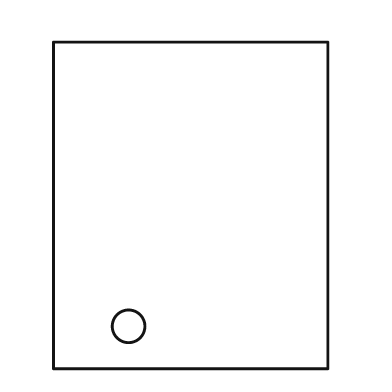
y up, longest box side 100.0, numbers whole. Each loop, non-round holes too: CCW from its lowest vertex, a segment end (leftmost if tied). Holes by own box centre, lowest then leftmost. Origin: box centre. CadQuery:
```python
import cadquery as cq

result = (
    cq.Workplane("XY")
    .moveTo(-42.0, -50.0)
    .lineTo(42.0, -50.0)
    .lineTo(42.0, 50.0)
    .lineTo(-42.0, 50.0)
    .close()
    .moveTo(-19.0, -37.0)
    .circle(5.0)
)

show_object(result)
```